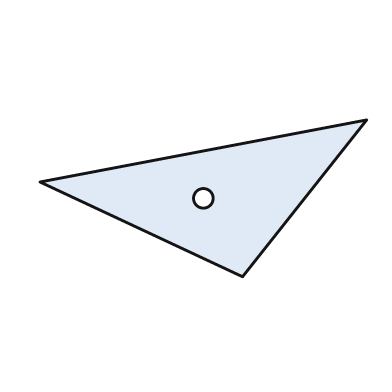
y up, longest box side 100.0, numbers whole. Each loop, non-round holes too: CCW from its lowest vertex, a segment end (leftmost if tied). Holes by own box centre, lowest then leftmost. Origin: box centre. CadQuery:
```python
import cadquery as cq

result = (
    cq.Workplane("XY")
    .moveTo(12.0, -24.0)
    .lineTo(50.0, 24.0)
    .lineTo(-50.0, 5.0)
    .close()
    .moveTo(0.0, 0.0)
    .circle(3.0)
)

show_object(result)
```